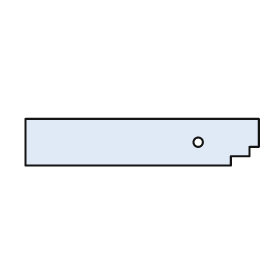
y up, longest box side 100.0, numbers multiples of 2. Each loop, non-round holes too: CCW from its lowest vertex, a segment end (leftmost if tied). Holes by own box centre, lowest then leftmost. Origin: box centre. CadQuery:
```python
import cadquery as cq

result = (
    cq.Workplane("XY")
    .moveTo(-50.0, -10.0)
    .lineTo(38.0, -10.0)
    .lineTo(38.0, -6.0)
    .lineTo(46.0, -6.0)
    .lineTo(46.0, -2.0)
    .lineTo(50.0, -2.0)
    .lineTo(50.0, 10.0)
    .lineTo(-50.0, 10.0)
    .close()
    .moveTo(24.0, 0.0)
    .circle(2.0)
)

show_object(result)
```